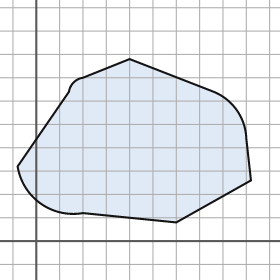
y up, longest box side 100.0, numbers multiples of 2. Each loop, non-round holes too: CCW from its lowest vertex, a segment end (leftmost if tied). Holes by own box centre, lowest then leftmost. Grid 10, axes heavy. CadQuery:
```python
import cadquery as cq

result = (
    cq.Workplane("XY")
    .moveTo(60.0, 8.0)
    .lineTo(92.0, 26.0)
    .lineTo(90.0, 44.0)
    .threePointArc((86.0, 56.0), (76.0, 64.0))
    .lineTo(40.0, 78.0)
    .lineTo(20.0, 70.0)
    .threePointArc((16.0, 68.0), (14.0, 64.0))
    .lineTo(-8.0, 32.0)
    .threePointArc((2.0, 16.0), (20.0, 12.0))
    .close()
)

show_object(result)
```